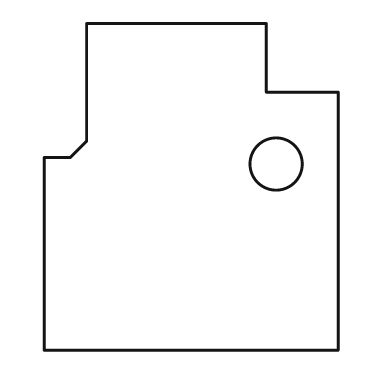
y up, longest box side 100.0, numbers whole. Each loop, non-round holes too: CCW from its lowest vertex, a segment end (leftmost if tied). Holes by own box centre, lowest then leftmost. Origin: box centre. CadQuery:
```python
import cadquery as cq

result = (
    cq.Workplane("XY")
    .moveTo(-45.0, -50.0)
    .lineTo(45.0, -50.0)
    .lineTo(45.0, 29.0)
    .lineTo(23.0, 29.0)
    .lineTo(23.0, 50.0)
    .lineTo(-32.0, 50.0)
    .lineTo(-32.0, 14.0)
    .lineTo(-37.0, 9.0)
    .lineTo(-45.0, 9.0)
    .close()
    .moveTo(26.0, 7.0)
    .circle(8.0)
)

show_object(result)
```